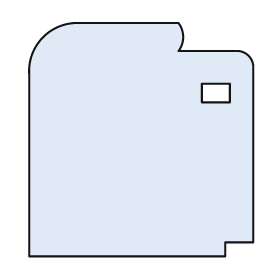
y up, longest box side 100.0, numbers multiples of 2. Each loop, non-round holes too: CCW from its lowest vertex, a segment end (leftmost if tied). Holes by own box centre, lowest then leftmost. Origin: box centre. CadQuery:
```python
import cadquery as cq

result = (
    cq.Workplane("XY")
    .moveTo(-48.0, -50.0)
    .lineTo(36.0, -50.0)
    .lineTo(36.0, -44.0)
    .lineTo(48.0, -44.0)
    .lineTo(48.0, 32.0)
    .threePointArc((46.0, 36.0), (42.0, 38.0))
    .lineTo(16.0, 38.0)
    .threePointArc((18.0, 44.0), (16.0, 50.0))
    .lineTo(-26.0, 50.0)
    .threePointArc((-42.0, 44.0), (-48.0, 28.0))
    .close()
    .moveTo(26.0, 16.0)
    .lineTo(38.0, 16.0)
    .lineTo(38.0, 24.0)
    .lineTo(26.0, 24.0)
    .close()
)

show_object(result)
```